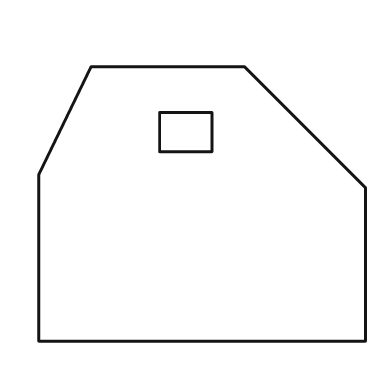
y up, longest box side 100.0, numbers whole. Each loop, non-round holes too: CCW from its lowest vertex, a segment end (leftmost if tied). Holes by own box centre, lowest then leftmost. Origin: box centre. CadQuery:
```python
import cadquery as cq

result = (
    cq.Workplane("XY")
    .moveTo(-50.0, -42.0)
    .lineTo(50.0, -42.0)
    .lineTo(50.0, 5.0)
    .lineTo(13.0, 42.0)
    .lineTo(-34.0, 42.0)
    .lineTo(-50.0, 9.0)
    .close()
    .moveTo(-13.0, 16.0)
    .lineTo(3.0, 16.0)
    .lineTo(3.0, 28.0)
    .lineTo(-13.0, 28.0)
    .close()
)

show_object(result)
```